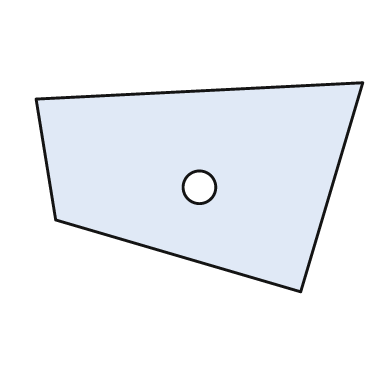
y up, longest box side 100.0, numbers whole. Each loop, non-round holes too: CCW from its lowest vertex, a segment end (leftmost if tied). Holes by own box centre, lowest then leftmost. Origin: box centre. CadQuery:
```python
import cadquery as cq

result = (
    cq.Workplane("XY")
    .moveTo(31.0, -32.0)
    .lineTo(50.0, 32.0)
    .lineTo(-50.0, 27.0)
    .lineTo(-44.0, -10.0)
    .close()
    .moveTo(0.0, 0.0)
    .circle(5.0)
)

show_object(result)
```